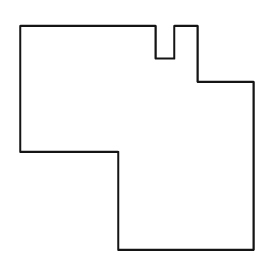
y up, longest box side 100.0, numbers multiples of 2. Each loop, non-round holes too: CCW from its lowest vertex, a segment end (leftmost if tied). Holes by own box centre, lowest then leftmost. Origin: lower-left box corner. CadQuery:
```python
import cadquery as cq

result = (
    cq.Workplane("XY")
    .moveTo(42.0, 0.0)
    .lineTo(100.0, 0.0)
    .lineTo(100.0, 72.0)
    .lineTo(76.0, 72.0)
    .lineTo(76.0, 96.0)
    .lineTo(66.0, 96.0)
    .lineTo(66.0, 82.0)
    .lineTo(58.0, 82.0)
    .lineTo(58.0, 96.0)
    .lineTo(0.0, 96.0)
    .lineTo(0.0, 42.0)
    .lineTo(42.0, 42.0)
    .close()
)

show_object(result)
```